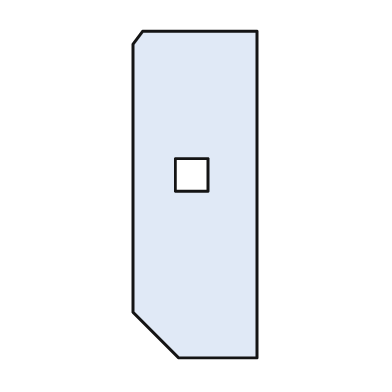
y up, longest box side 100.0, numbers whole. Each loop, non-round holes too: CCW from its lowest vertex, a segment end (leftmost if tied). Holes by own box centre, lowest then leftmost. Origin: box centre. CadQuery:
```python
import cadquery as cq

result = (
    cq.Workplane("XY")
    .moveTo(-5.0, -50.0)
    .lineTo(19.0, -50.0)
    .lineTo(19.0, 50.0)
    .lineTo(-16.0, 50.0)
    .lineTo(-19.0, 46.0)
    .lineTo(-19.0, -36.0)
    .close()
    .moveTo(-6.0, 1.0)
    .lineTo(4.0, 1.0)
    .lineTo(4.0, 11.0)
    .lineTo(-6.0, 11.0)
    .close()
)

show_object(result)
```